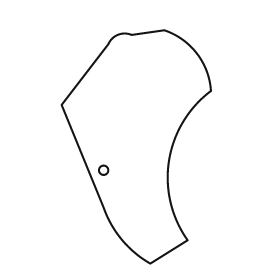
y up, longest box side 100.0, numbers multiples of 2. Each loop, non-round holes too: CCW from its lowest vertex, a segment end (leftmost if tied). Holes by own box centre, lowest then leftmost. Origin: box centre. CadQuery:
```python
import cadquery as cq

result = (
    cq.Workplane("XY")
    .moveTo(6.0, -50.0)
    .lineTo(22.0, -40.0)
    .threePointArc((14.0, -6.0), (32.0, 24.0))
    .threePointArc((26.0, 40.0), (12.0, 50.0))
    .lineTo(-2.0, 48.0)
    .threePointArc((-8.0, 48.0), (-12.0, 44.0))
    .lineTo(-32.0, 18.0)
    .lineTo(-14.0, -26.0)
    .threePointArc((-6.0, -40.0), (6.0, -50.0))
    .close()
    .moveTo(-14.0, -10.0)
    .circle(2.0)
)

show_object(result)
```